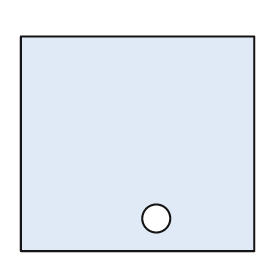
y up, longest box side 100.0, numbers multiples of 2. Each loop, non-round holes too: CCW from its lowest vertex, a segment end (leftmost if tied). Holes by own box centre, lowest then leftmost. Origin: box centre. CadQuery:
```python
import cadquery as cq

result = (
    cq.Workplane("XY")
    .moveTo(-50.0, -46.0)
    .lineTo(50.0, -46.0)
    .lineTo(50.0, 46.0)
    .lineTo(-50.0, 46.0)
    .close()
    .moveTo(8.0, -32.0)
    .circle(6.0)
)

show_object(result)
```